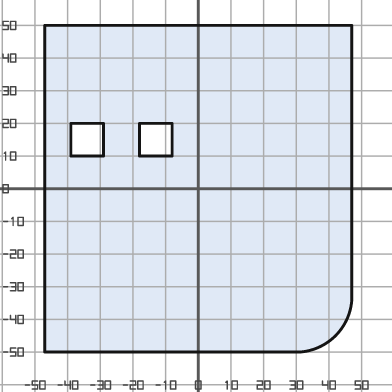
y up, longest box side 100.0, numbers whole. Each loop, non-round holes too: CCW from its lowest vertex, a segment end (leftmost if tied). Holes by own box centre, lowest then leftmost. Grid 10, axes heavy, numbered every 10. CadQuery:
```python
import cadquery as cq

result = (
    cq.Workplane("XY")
    .moveTo(-47.0, -50.0)
    .lineTo(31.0, -50.0)
    .threePointArc((42.0, -45.0), (47.0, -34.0))
    .lineTo(47.0, 50.0)
    .lineTo(-47.0, 50.0)
    .close()
    .moveTo(-39.0, 10.0)
    .lineTo(-29.0, 10.0)
    .lineTo(-29.0, 20.0)
    .lineTo(-39.0, 20.0)
    .close()
    .moveTo(-18.0, 10.0)
    .lineTo(-8.0, 10.0)
    .lineTo(-8.0, 20.0)
    .lineTo(-18.0, 20.0)
    .close()
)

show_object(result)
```